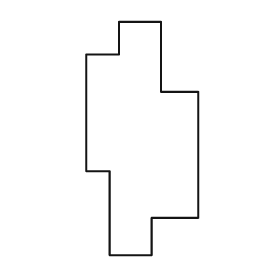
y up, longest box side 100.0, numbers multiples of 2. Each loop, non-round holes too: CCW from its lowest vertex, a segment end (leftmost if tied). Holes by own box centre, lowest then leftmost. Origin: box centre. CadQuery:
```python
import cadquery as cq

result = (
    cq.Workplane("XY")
    .moveTo(-14.0, -50.0)
    .lineTo(4.0, -50.0)
    .lineTo(4.0, -34.0)
    .lineTo(24.0, -34.0)
    .lineTo(24.0, 20.0)
    .lineTo(8.0, 20.0)
    .lineTo(8.0, 50.0)
    .lineTo(-10.0, 50.0)
    .lineTo(-10.0, 36.0)
    .lineTo(-24.0, 36.0)
    .lineTo(-24.0, -14.0)
    .lineTo(-14.0, -14.0)
    .close()
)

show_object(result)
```